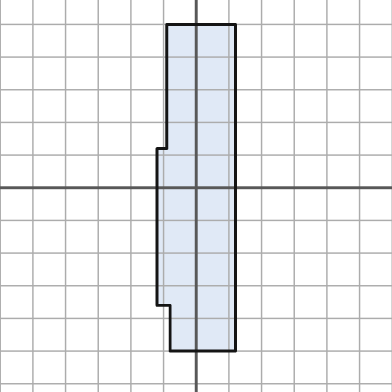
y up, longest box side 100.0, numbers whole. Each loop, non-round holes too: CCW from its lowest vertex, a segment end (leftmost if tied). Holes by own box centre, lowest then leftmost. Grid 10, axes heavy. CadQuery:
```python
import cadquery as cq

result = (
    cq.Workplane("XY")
    .moveTo(-8.0, -50.0)
    .lineTo(12.0, -50.0)
    .lineTo(12.0, 50.0)
    .lineTo(-9.0, 50.0)
    .lineTo(-9.0, 12.0)
    .lineTo(-12.0, 12.0)
    .lineTo(-12.0, -36.0)
    .lineTo(-8.0, -36.0)
    .close()
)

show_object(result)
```